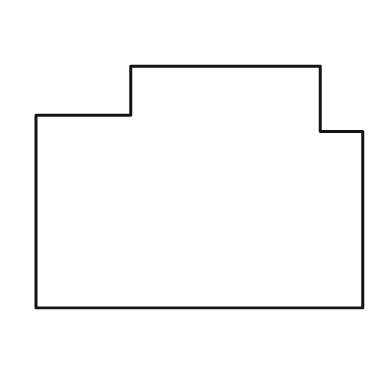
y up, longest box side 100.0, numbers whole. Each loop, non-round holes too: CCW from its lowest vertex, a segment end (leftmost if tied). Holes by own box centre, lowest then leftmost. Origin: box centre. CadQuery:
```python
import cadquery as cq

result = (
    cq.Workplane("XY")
    .moveTo(-50.0, -37.0)
    .lineTo(50.0, -37.0)
    .lineTo(50.0, 17.0)
    .lineTo(37.0, 17.0)
    .lineTo(37.0, 37.0)
    .lineTo(-21.0, 37.0)
    .lineTo(-21.0, 22.0)
    .lineTo(-50.0, 22.0)
    .close()
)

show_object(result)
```